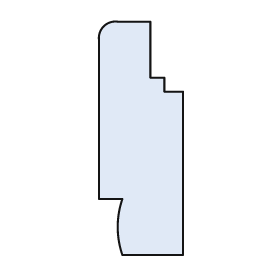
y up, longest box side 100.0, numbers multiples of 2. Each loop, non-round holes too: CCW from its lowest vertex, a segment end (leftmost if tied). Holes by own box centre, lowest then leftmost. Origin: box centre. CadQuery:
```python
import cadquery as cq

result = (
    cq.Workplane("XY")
    .moveTo(-8.0, -50.0)
    .lineTo(18.0, -50.0)
    .lineTo(18.0, 20.0)
    .lineTo(10.0, 20.0)
    .lineTo(10.0, 26.0)
    .lineTo(4.0, 26.0)
    .lineTo(4.0, 50.0)
    .lineTo(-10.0, 50.0)
    .threePointArc((-16.0, 48.0), (-18.0, 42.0))
    .lineTo(-18.0, -26.0)
    .lineTo(-8.0, -26.0)
    .threePointArc((-10.0, -38.0), (-8.0, -50.0))
    .close()
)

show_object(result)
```